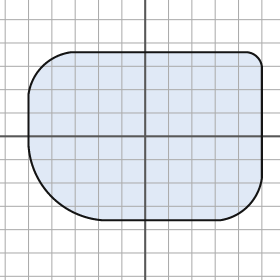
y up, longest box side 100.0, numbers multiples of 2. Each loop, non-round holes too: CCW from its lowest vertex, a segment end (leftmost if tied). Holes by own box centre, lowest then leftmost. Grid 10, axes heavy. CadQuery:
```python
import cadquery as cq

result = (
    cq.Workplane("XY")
    .moveTo(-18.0, -36.0)
    .lineTo(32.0, -36.0)
    .threePointArc((44.0, -30.0), (50.0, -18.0))
    .lineTo(50.0, 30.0)
    .threePointArc((48.0, 34.0), (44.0, 36.0))
    .lineTo(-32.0, 36.0)
    .threePointArc((-44.0, 30.0), (-50.0, 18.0))
    .lineTo(-50.0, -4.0)
    .threePointArc((-40.0, -26.0), (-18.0, -36.0))
    .close()
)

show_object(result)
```